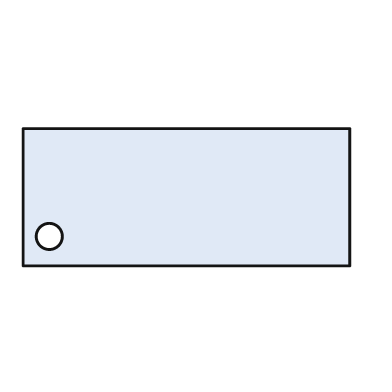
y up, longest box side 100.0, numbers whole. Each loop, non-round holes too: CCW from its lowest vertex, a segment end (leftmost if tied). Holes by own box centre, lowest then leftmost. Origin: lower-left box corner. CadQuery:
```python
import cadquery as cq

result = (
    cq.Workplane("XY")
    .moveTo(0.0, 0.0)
    .lineTo(100.0, 0.0)
    .lineTo(100.0, 42.0)
    .lineTo(0.0, 42.0)
    .close()
    .moveTo(8.0, 9.0)
    .circle(4.0)
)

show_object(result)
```